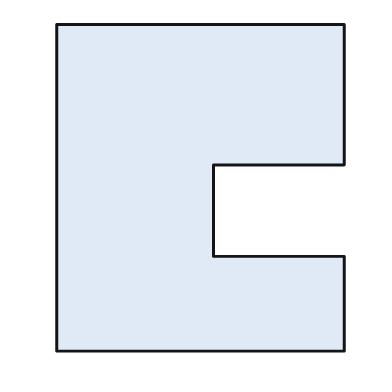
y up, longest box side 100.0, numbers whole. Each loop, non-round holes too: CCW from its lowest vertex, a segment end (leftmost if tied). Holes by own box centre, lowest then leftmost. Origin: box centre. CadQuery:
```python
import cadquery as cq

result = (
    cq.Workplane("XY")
    .moveTo(-44.0, -50.0)
    .lineTo(44.0, -50.0)
    .lineTo(44.0, -21.0)
    .lineTo(4.0, -21.0)
    .lineTo(4.0, 7.0)
    .lineTo(44.0, 7.0)
    .lineTo(44.0, 50.0)
    .lineTo(-44.0, 50.0)
    .close()
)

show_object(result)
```